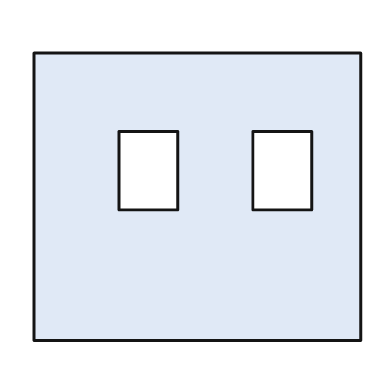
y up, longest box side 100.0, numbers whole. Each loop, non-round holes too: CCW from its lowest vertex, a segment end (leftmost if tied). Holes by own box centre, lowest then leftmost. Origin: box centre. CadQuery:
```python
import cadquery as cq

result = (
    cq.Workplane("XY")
    .moveTo(-50.0, -44.0)
    .lineTo(50.0, -44.0)
    .lineTo(50.0, 44.0)
    .lineTo(-50.0, 44.0)
    .close()
    .moveTo(-24.0, -4.0)
    .lineTo(-6.0, -4.0)
    .lineTo(-6.0, 20.0)
    .lineTo(-24.0, 20.0)
    .close()
    .moveTo(17.0, -4.0)
    .lineTo(35.0, -4.0)
    .lineTo(35.0, 20.0)
    .lineTo(17.0, 20.0)
    .close()
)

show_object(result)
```